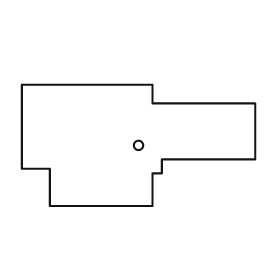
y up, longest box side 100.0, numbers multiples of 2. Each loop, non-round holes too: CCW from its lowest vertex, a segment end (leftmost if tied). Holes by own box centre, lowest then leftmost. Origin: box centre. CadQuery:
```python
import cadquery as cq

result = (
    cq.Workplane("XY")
    .moveTo(-38.0, -26.0)
    .lineTo(6.0, -26.0)
    .lineTo(6.0, -12.0)
    .lineTo(10.0, -12.0)
    .lineTo(10.0, -6.0)
    .lineTo(50.0, -6.0)
    .lineTo(50.0, 18.0)
    .lineTo(6.0, 18.0)
    .lineTo(6.0, 26.0)
    .lineTo(-50.0, 26.0)
    .lineTo(-50.0, -10.0)
    .lineTo(-38.0, -10.0)
    .close()
    .moveTo(0.0, 0.0)
    .circle(2.0)
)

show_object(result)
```